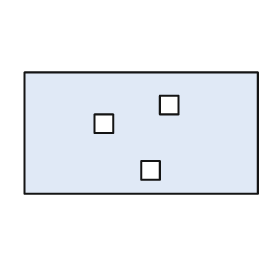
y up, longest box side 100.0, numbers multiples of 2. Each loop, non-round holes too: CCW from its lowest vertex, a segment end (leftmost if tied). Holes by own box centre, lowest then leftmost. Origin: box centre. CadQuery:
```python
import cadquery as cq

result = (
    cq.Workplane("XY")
    .moveTo(-50.0, -26.0)
    .lineTo(50.0, -26.0)
    .lineTo(50.0, 26.0)
    .lineTo(-50.0, 26.0)
    .close()
    .moveTo(0.0, -20.0)
    .lineTo(8.0, -20.0)
    .lineTo(8.0, -12.0)
    .lineTo(0.0, -12.0)
    .close()
    .moveTo(-20.0, 0.0)
    .lineTo(-12.0, 0.0)
    .lineTo(-12.0, 8.0)
    .lineTo(-20.0, 8.0)
    .close()
    .moveTo(8.0, 8.0)
    .lineTo(16.0, 8.0)
    .lineTo(16.0, 16.0)
    .lineTo(8.0, 16.0)
    .close()
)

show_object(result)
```